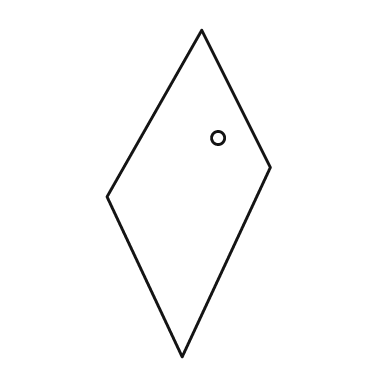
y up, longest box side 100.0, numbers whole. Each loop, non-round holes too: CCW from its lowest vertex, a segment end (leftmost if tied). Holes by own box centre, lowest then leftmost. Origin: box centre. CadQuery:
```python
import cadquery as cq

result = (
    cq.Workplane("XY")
    .moveTo(-2.0, -50.0)
    .lineTo(25.0, 8.0)
    .lineTo(4.0, 50.0)
    .lineTo(-25.0, -1.0)
    .close()
    .moveTo(9.0, 17.0)
    .circle(2.0)
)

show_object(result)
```